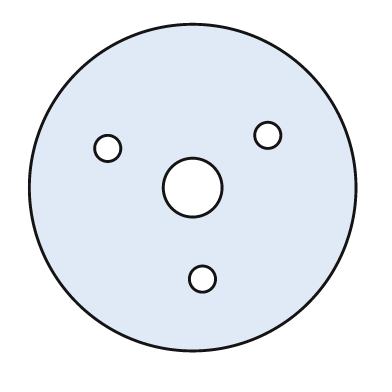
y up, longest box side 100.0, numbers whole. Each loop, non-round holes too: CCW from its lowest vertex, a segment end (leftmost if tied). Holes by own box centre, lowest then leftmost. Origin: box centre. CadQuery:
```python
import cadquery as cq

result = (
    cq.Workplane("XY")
    .moveTo(0.0, 0.0)
    .circle(50.0)
    .moveTo(3.0, -28.0)
    .circle(4.0)
    .moveTo(0.0, 0.0)
    .circle(9.0)
    .moveTo(-26.0, 12.0)
    .circle(4.0)
    .moveTo(23.0, 16.0)
    .circle(4.0)
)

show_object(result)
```